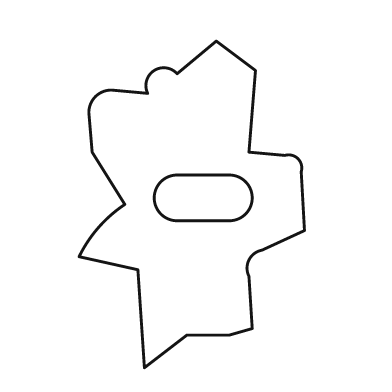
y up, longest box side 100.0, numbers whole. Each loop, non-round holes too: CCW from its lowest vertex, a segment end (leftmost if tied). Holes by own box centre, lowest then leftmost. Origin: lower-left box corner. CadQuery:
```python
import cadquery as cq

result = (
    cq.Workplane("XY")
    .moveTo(20.0, 0.0)
    .lineTo(33.0, 10.0)
    .lineTo(46.0, 10.0)
    .lineTo(53.0, 12.0)
    .lineTo(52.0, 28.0)
    .threePointArc((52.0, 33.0), (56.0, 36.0))
    .lineTo(69.0, 42.0)
    .lineTo(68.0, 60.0)
    .threePointArc((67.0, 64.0), (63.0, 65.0))
    .lineTo(52.0, 66.0)
    .lineTo(54.0, 91.0)
    .lineTo(42.0, 100.0)
    .lineTo(30.0, 90.0)
    .threePointArc((23.0, 91.0), (21.0, 84.0))
    .lineTo(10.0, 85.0)
    .threePointArc((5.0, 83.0), (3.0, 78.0))
    .lineTo(4.0, 66.0)
    .lineTo(14.0, 50.0)
    .threePointArc((6.0, 43.0), (0.0, 34.0))
    .lineTo(18.0, 30.0)
    .close()
    .moveTo(30.0, 45.0)
    .lineTo(46.0, 45.0)
    .threePointArc((53.0, 52.0), (46.0, 59.0))
    .lineTo(30.0, 59.0)
    .threePointArc((23.0, 52.0), (30.0, 45.0))
    .close()
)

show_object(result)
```